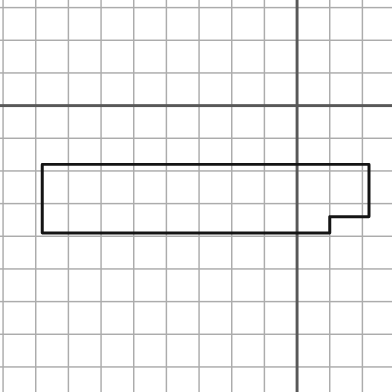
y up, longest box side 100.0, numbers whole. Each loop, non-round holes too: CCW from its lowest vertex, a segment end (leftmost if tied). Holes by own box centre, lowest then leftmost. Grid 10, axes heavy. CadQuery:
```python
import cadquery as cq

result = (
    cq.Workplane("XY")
    .moveTo(-78.0, -39.0)
    .lineTo(10.0, -39.0)
    .lineTo(10.0, -34.0)
    .lineTo(22.0, -34.0)
    .lineTo(22.0, -18.0)
    .lineTo(-78.0, -18.0)
    .close()
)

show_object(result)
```